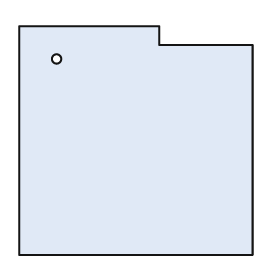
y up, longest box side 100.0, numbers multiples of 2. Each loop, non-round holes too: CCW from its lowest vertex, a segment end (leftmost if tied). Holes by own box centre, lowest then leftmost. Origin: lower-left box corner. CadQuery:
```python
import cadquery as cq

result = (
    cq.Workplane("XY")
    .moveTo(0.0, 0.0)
    .lineTo(100.0, 0.0)
    .lineTo(100.0, 90.0)
    .lineTo(60.0, 90.0)
    .lineTo(60.0, 98.0)
    .lineTo(0.0, 98.0)
    .close()
    .moveTo(16.0, 84.0)
    .circle(2.0)
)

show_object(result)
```